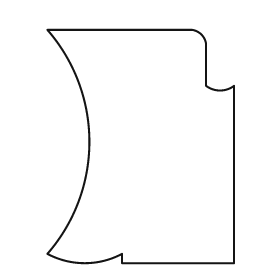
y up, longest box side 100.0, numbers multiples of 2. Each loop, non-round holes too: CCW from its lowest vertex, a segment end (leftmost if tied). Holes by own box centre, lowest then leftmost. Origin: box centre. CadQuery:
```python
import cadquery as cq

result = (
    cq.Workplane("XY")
    .moveTo(-8.0, -50.0)
    .lineTo(40.0, -50.0)
    .lineTo(40.0, 26.0)
    .threePointArc((34.0, 24.0), (28.0, 26.0))
    .lineTo(28.0, 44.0)
    .threePointArc((26.0, 48.0), (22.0, 50.0))
    .lineTo(-40.0, 50.0)
    .threePointArc((-22.0, 2.0), (-40.0, -46.0))
    .threePointArc((-24.0, -50.0), (-8.0, -46.0))
    .close()
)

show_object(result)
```